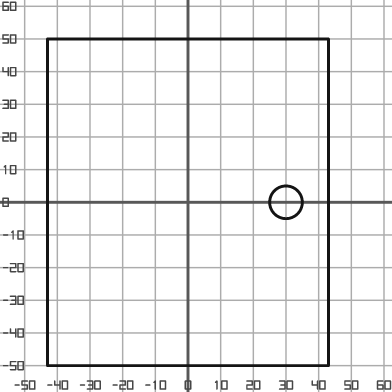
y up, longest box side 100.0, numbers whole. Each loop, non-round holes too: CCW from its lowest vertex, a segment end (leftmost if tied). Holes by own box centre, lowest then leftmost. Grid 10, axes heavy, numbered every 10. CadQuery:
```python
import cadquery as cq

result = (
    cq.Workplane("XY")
    .moveTo(-43.0, -50.0)
    .lineTo(43.0, -50.0)
    .lineTo(43.0, 50.0)
    .lineTo(-43.0, 50.0)
    .close()
    .moveTo(30.0, 0.0)
    .circle(5.0)
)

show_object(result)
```